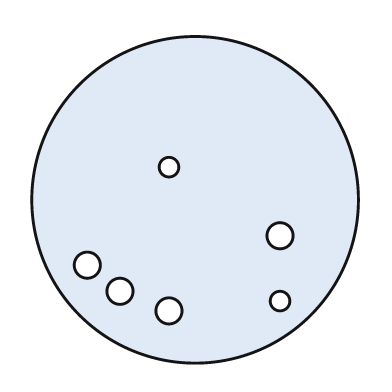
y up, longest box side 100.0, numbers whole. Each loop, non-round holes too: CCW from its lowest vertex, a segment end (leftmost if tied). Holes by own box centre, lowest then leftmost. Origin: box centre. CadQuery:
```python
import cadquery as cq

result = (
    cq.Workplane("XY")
    .moveTo(0.0, 0.0)
    .circle(50.0)
    .moveTo(-8.0, -34.0)
    .circle(4.0)
    .moveTo(26.0, -31.0)
    .circle(3.0)
    .moveTo(-23.0, -28.0)
    .circle(4.0)
    .moveTo(-33.0, -20.0)
    .circle(4.0)
    .moveTo(26.0, -11.0)
    .circle(4.0)
    .moveTo(-8.0, 10.0)
    .circle(3.0)
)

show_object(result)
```